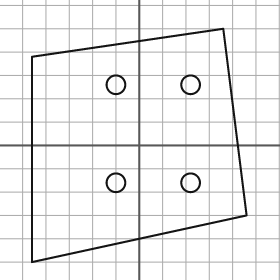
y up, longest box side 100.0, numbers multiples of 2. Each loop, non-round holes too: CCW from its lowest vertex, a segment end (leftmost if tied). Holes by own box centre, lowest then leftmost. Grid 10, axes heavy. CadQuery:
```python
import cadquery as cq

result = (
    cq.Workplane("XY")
    .moveTo(-46.0, -50.0)
    .lineTo(46.0, -30.0)
    .lineTo(36.0, 50.0)
    .lineTo(-46.0, 38.0)
    .close()
    .moveTo(-10.0, -16.0)
    .circle(4.0)
    .moveTo(22.0, -16.0)
    .circle(4.0)
    .moveTo(-10.0, 26.0)
    .circle(4.0)
    .moveTo(22.0, 26.0)
    .circle(4.0)
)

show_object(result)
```